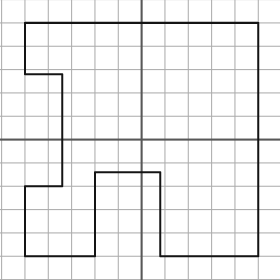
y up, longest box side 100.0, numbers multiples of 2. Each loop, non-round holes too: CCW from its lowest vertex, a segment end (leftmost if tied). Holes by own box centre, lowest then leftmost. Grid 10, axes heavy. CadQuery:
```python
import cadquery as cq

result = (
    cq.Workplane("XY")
    .moveTo(-50.0, -50.0)
    .lineTo(-20.0, -50.0)
    .lineTo(-20.0, -14.0)
    .lineTo(8.0, -14.0)
    .lineTo(8.0, -50.0)
    .lineTo(50.0, -50.0)
    .lineTo(50.0, 50.0)
    .lineTo(-50.0, 50.0)
    .lineTo(-50.0, 28.0)
    .lineTo(-34.0, 28.0)
    .lineTo(-34.0, -20.0)
    .lineTo(-50.0, -20.0)
    .close()
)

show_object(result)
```